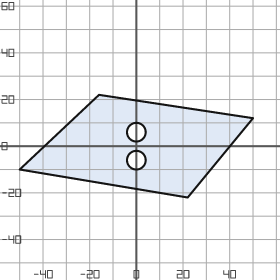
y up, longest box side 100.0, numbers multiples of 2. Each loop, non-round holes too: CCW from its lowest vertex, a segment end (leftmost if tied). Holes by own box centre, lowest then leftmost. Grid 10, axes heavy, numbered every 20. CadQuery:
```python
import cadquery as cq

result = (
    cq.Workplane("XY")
    .moveTo(22.0, -22.0)
    .lineTo(50.0, 12.0)
    .lineTo(-16.0, 22.0)
    .lineTo(-50.0, -10.0)
    .close()
    .moveTo(0.0, -6.0)
    .circle(4.0)
    .moveTo(0.0, 6.0)
    .circle(4.0)
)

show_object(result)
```